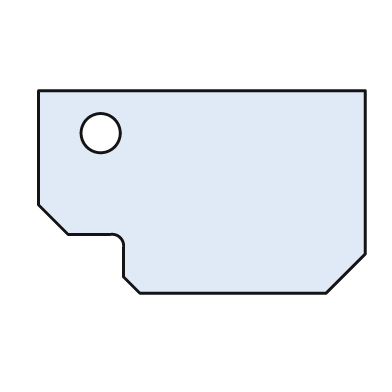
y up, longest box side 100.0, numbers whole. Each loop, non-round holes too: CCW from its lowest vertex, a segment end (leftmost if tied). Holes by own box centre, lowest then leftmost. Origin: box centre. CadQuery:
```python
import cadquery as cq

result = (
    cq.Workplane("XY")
    .moveTo(-19.0, -31.0)
    .lineTo(38.0, -31.0)
    .lineTo(50.0, -19.0)
    .lineTo(50.0, 31.0)
    .lineTo(-50.0, 31.0)
    .lineTo(-50.0, -4.0)
    .lineTo(-41.0, -13.0)
    .lineTo(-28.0, -13.0)
    .threePointArc((-25.0, -14.0), (-24.0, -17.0))
    .lineTo(-24.0, -26.0)
    .close()
    .moveTo(-31.0, 18.0)
    .circle(6.0)
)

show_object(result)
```